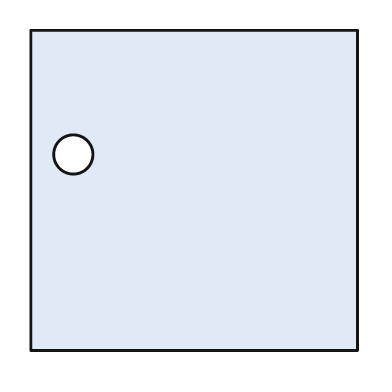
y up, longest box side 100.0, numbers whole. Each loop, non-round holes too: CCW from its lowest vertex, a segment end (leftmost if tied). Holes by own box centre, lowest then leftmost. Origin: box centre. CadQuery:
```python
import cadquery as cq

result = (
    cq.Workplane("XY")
    .moveTo(-50.0, -49.0)
    .lineTo(50.0, -49.0)
    .lineTo(50.0, 49.0)
    .lineTo(-50.0, 49.0)
    .close()
    .moveTo(-37.0, 11.0)
    .circle(6.0)
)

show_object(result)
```